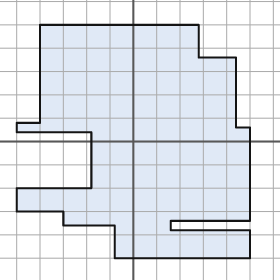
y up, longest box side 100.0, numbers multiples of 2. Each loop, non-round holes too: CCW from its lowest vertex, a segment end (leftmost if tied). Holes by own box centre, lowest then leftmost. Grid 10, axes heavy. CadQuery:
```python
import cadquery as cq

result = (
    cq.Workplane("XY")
    .moveTo(-8.0, -50.0)
    .lineTo(50.0, -50.0)
    .lineTo(50.0, -38.0)
    .lineTo(16.0, -38.0)
    .lineTo(16.0, -34.0)
    .lineTo(50.0, -34.0)
    .lineTo(50.0, 6.0)
    .lineTo(44.0, 6.0)
    .lineTo(44.0, 36.0)
    .lineTo(28.0, 36.0)
    .lineTo(28.0, 50.0)
    .lineTo(-40.0, 50.0)
    .lineTo(-40.0, 8.0)
    .lineTo(-50.0, 8.0)
    .lineTo(-50.0, 4.0)
    .lineTo(-18.0, 4.0)
    .lineTo(-18.0, -20.0)
    .lineTo(-50.0, -20.0)
    .lineTo(-50.0, -30.0)
    .lineTo(-30.0, -30.0)
    .lineTo(-30.0, -36.0)
    .lineTo(-8.0, -36.0)
    .close()
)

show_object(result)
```